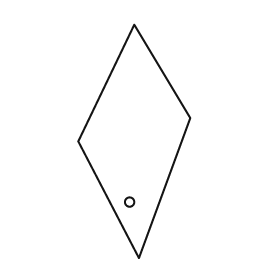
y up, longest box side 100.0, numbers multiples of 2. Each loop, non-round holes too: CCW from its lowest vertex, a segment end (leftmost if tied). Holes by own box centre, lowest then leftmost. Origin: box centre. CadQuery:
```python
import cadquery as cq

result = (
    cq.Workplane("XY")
    .moveTo(2.0, -50.0)
    .lineTo(24.0, 10.0)
    .lineTo(0.0, 50.0)
    .lineTo(-24.0, 0.0)
    .close()
    .moveTo(-2.0, -26.0)
    .circle(2.0)
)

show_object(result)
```